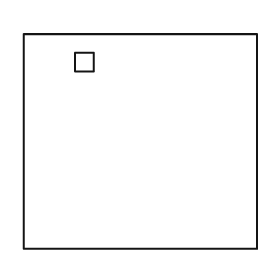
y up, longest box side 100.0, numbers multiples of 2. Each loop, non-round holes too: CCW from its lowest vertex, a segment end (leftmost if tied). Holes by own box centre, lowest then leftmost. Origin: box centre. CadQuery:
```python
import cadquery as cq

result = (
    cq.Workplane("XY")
    .moveTo(-50.0, -46.0)
    .lineTo(50.0, -46.0)
    .lineTo(50.0, 46.0)
    .lineTo(-50.0, 46.0)
    .close()
    .moveTo(-28.0, 30.0)
    .lineTo(-20.0, 30.0)
    .lineTo(-20.0, 38.0)
    .lineTo(-28.0, 38.0)
    .close()
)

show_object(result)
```